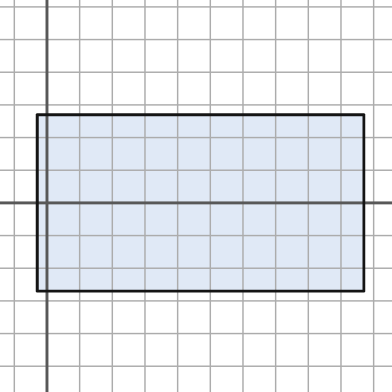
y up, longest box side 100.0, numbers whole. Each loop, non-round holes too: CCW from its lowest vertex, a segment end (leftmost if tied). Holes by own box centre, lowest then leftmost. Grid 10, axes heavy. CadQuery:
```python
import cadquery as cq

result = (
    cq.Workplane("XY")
    .moveTo(-3.0, -27.0)
    .lineTo(97.0, -27.0)
    .lineTo(97.0, 27.0)
    .lineTo(-3.0, 27.0)
    .close()
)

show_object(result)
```